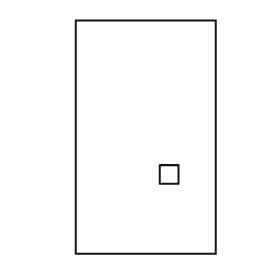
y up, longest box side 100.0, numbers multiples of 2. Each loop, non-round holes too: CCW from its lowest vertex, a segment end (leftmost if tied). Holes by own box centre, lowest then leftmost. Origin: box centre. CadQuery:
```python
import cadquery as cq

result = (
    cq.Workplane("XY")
    .moveTo(-30.0, -50.0)
    .lineTo(30.0, -50.0)
    .lineTo(30.0, 50.0)
    .lineTo(-30.0, 50.0)
    .close()
    .moveTo(6.0, -20.0)
    .lineTo(14.0, -20.0)
    .lineTo(14.0, -12.0)
    .lineTo(6.0, -12.0)
    .close()
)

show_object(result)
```